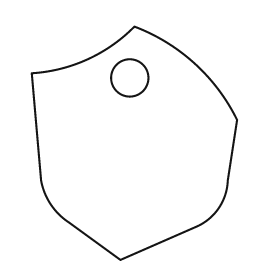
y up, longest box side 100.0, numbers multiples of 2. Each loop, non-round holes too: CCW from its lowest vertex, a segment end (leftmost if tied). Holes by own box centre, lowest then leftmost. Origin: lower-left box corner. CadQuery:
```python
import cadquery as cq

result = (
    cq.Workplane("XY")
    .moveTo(38.0, 0.0)
    .lineTo(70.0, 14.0)
    .threePointArc((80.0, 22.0), (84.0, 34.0))
    .lineTo(88.0, 60.0)
    .threePointArc((70.0, 84.0), (44.0, 100.0))
    .threePointArc((24.0, 86.0), (0.0, 80.0))
    .lineTo(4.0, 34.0)
    .threePointArc((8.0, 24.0), (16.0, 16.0))
    .close()
    .moveTo(42.0, 78.0)
    .circle(8.0)
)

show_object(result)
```